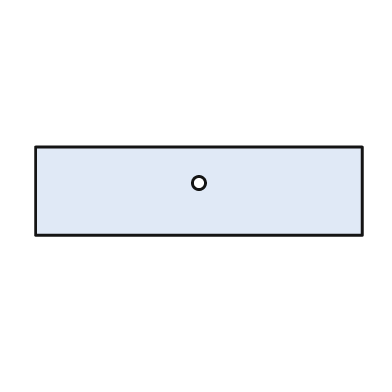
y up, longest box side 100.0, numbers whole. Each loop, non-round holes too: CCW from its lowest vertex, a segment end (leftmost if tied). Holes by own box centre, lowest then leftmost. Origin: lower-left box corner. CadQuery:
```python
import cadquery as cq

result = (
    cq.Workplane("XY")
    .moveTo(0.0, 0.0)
    .lineTo(100.0, 0.0)
    .lineTo(100.0, 27.0)
    .lineTo(0.0, 27.0)
    .close()
    .moveTo(50.0, 16.0)
    .circle(2.0)
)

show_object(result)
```